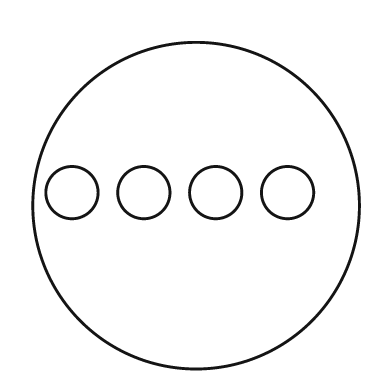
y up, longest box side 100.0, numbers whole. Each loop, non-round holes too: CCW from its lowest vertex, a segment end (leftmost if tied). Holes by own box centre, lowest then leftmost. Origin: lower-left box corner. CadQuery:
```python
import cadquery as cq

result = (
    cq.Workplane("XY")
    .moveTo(50.0, 50.0)
    .circle(50.0)
    .moveTo(12.0, 54.0)
    .circle(8.0)
    .moveTo(34.0, 54.0)
    .circle(8.0)
    .moveTo(56.0, 54.0)
    .circle(8.0)
    .moveTo(78.0, 54.0)
    .circle(8.0)
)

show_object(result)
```